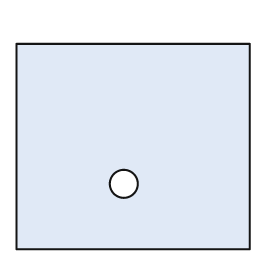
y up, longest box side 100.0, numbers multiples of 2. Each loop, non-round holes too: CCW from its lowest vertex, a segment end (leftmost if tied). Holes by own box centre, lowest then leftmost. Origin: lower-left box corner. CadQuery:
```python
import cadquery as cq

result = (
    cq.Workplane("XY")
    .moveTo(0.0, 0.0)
    .lineTo(100.0, 0.0)
    .lineTo(100.0, 88.0)
    .lineTo(0.0, 88.0)
    .close()
    .moveTo(46.0, 28.0)
    .circle(6.0)
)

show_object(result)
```